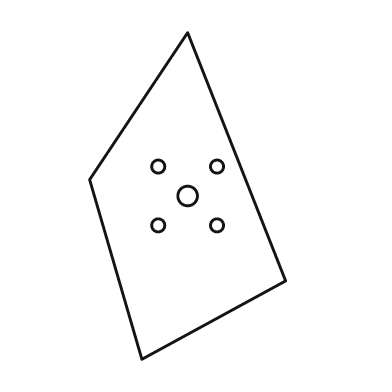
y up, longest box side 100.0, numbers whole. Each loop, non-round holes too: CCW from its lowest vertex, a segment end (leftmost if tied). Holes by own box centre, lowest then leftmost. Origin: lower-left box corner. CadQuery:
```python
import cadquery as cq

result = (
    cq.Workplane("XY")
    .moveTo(16.0, 0.0)
    .lineTo(60.0, 24.0)
    .lineTo(30.0, 100.0)
    .lineTo(0.0, 55.0)
    .close()
    .moveTo(21.0, 41.0)
    .circle(2.0)
    .moveTo(39.0, 41.0)
    .circle(2.0)
    .moveTo(30.0, 50.0)
    .circle(3.0)
    .moveTo(21.0, 59.0)
    .circle(2.0)
    .moveTo(39.0, 59.0)
    .circle(2.0)
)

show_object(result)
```